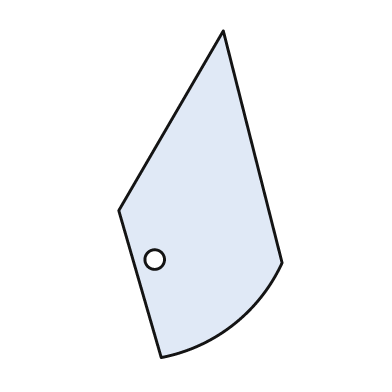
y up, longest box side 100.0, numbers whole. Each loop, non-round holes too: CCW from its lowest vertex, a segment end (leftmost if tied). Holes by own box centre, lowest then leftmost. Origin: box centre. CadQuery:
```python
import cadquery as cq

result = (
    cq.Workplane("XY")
    .moveTo(-12.0, -50.0)
    .threePointArc((10.0, -40.0), (25.0, -21.0))
    .lineTo(7.0, 50.0)
    .lineTo(-25.0, -5.0)
    .close()
    .moveTo(-14.0, -20.0)
    .circle(3.0)
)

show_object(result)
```